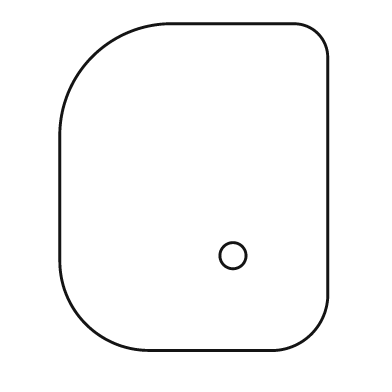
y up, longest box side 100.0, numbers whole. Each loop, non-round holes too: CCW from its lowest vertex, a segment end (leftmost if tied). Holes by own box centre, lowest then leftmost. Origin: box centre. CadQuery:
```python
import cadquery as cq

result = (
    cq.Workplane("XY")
    .moveTo(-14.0, -50.0)
    .lineTo(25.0, -50.0)
    .threePointArc((36.0, -45.0), (41.0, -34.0))
    .lineTo(41.0, 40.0)
    .threePointArc((38.0, 47.0), (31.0, 50.0))
    .lineTo(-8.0, 50.0)
    .threePointArc((-31.0, 40.0), (-41.0, 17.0))
    .lineTo(-41.0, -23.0)
    .threePointArc((-33.0, -42.0), (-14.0, -50.0))
    .close()
    .moveTo(12.0, -21.0)
    .circle(4.0)
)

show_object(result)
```